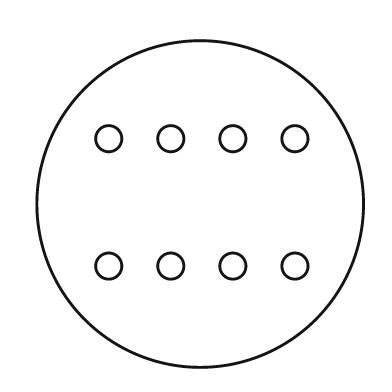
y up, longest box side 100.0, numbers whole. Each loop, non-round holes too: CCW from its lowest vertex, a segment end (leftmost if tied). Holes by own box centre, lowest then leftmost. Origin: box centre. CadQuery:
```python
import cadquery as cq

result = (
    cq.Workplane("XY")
    .moveTo(0.0, 0.0)
    .circle(50.0)
    .moveTo(-28.0, -19.0)
    .circle(4.0)
    .moveTo(-9.0, -19.0)
    .circle(4.0)
    .moveTo(10.0, -19.0)
    .circle(4.0)
    .moveTo(29.0, -19.0)
    .circle(4.0)
    .moveTo(-28.0, 20.0)
    .circle(4.0)
    .moveTo(-9.0, 20.0)
    .circle(4.0)
    .moveTo(10.0, 20.0)
    .circle(4.0)
    .moveTo(29.0, 20.0)
    .circle(4.0)
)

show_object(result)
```